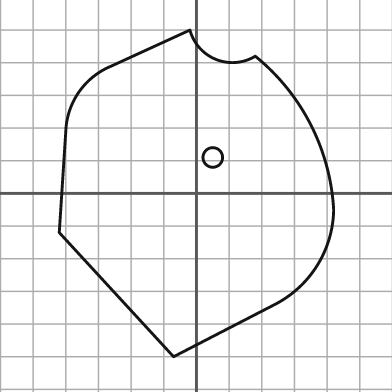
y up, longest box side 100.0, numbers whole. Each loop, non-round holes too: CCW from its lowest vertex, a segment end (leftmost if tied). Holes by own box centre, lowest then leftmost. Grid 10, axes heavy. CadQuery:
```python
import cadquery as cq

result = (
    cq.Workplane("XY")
    .moveTo(-7.0, -50.0)
    .lineTo(24.0, -34.0)
    .threePointArc((37.0, -22.0), (42.0, -5.0))
    .threePointArc((35.0, 21.0), (18.0, 42.0))
    .threePointArc((6.0, 41.0), (-2.0, 50.0))
    .lineTo(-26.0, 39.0)
    .threePointArc((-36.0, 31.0), (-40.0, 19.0))
    .lineTo(-42.0, -12.0)
    .close()
    .moveTo(5.0, 11.0)
    .circle(3.0)
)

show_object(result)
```